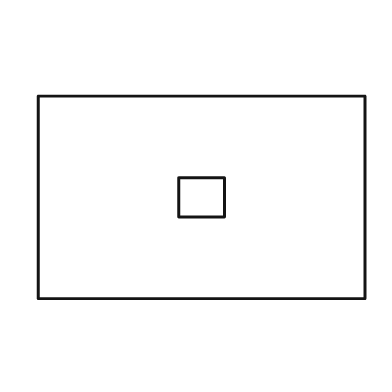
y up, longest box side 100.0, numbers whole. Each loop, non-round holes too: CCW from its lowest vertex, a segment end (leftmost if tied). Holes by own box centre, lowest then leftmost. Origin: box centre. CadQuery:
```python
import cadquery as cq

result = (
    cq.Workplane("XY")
    .moveTo(-50.0, -31.0)
    .lineTo(50.0, -31.0)
    .lineTo(50.0, 31.0)
    .lineTo(-50.0, 31.0)
    .close()
    .moveTo(-7.0, -6.0)
    .lineTo(7.0, -6.0)
    .lineTo(7.0, 6.0)
    .lineTo(-7.0, 6.0)
    .close()
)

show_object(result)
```